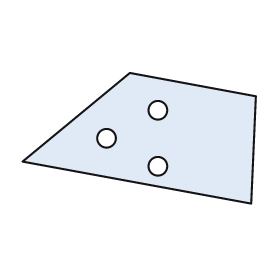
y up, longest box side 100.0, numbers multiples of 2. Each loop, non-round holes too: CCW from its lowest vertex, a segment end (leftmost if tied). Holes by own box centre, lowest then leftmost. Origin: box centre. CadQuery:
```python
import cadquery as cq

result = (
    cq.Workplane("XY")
    .moveTo(48.0, -28.0)
    .lineTo(50.0, 18.0)
    .lineTo(-4.0, 28.0)
    .lineTo(-50.0, -10.0)
    .close()
    .moveTo(8.0, -12.0)
    .circle(4.0)
    .moveTo(-14.0, 0.0)
    .circle(4.0)
    .moveTo(8.0, 12.0)
    .circle(4.0)
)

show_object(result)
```